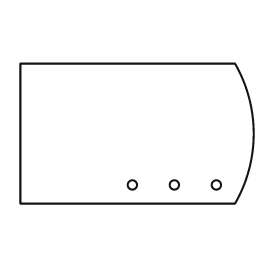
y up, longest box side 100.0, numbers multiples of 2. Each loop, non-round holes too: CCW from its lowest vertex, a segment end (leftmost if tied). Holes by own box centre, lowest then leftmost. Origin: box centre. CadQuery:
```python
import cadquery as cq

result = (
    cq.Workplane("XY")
    .moveTo(-50.0, -30.0)
    .lineTo(42.0, -30.0)
    .threePointArc((50.0, 0.0), (42.0, 30.0))
    .lineTo(-50.0, 30.0)
    .close()
    .moveTo(-2.0, -22.0)
    .circle(2.0)
    .moveTo(16.0, -22.0)
    .circle(2.0)
    .moveTo(34.0, -22.0)
    .circle(2.0)
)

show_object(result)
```